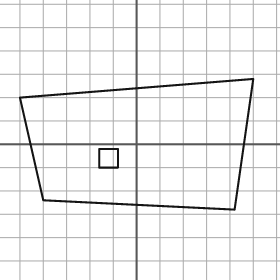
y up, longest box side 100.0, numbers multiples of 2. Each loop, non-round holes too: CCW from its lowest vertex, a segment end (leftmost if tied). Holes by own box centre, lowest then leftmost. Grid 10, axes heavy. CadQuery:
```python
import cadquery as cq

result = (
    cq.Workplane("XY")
    .moveTo(42.0, -28.0)
    .lineTo(50.0, 28.0)
    .lineTo(-50.0, 20.0)
    .lineTo(-40.0, -24.0)
    .close()
    .moveTo(-16.0, -10.0)
    .lineTo(-8.0, -10.0)
    .lineTo(-8.0, -2.0)
    .lineTo(-16.0, -2.0)
    .close()
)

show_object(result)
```